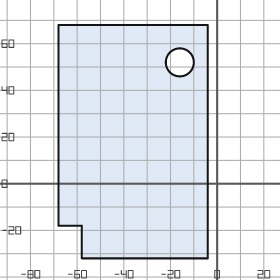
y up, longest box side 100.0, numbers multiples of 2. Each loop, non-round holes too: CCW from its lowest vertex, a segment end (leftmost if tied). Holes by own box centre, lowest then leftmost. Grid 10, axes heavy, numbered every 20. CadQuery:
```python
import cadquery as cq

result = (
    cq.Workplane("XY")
    .moveTo(-58.0, -32.0)
    .lineTo(-4.0, -32.0)
    .lineTo(-4.0, 68.0)
    .lineTo(-68.0, 68.0)
    .lineTo(-68.0, -18.0)
    .lineTo(-58.0, -18.0)
    .close()
    .moveTo(-16.0, 52.0)
    .circle(6.0)
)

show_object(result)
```